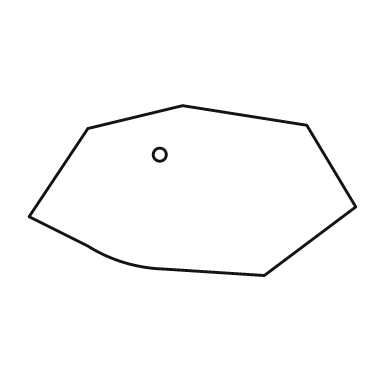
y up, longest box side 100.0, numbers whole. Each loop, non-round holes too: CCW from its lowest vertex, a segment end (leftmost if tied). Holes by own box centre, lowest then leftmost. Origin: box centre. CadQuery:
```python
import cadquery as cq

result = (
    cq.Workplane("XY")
    .moveTo(22.0, -26.0)
    .lineTo(50.0, -5.0)
    .lineTo(35.0, 20.0)
    .lineTo(-3.0, 26.0)
    .lineTo(-32.0, 19.0)
    .lineTo(-50.0, -8.0)
    .lineTo(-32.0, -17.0)
    .threePointArc((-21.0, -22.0), (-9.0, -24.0))
    .close()
    .moveTo(-10.0, 11.0)
    .circle(2.0)
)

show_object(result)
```